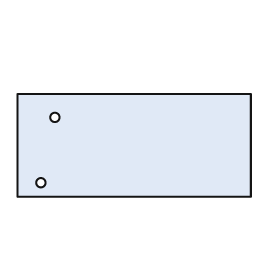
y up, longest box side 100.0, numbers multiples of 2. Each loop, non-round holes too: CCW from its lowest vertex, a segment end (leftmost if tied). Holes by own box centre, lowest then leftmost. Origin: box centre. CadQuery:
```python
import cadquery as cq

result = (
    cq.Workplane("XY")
    .moveTo(-50.0, -22.0)
    .lineTo(50.0, -22.0)
    .lineTo(50.0, 22.0)
    .lineTo(-50.0, 22.0)
    .close()
    .moveTo(-40.0, -16.0)
    .circle(2.0)
    .moveTo(-34.0, 12.0)
    .circle(2.0)
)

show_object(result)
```